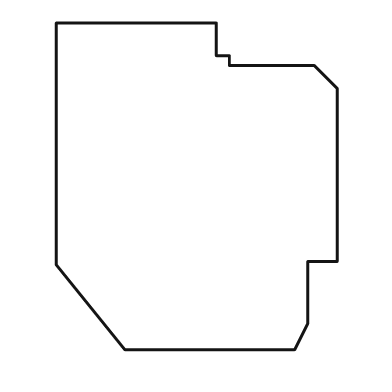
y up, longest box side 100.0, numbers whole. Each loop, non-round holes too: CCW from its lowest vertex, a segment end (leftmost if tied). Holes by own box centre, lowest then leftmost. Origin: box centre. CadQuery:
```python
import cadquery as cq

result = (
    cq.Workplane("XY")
    .moveTo(-22.0, -50.0)
    .lineTo(30.0, -50.0)
    .lineTo(34.0, -42.0)
    .lineTo(34.0, -23.0)
    .lineTo(43.0, -23.0)
    .lineTo(43.0, 30.0)
    .lineTo(36.0, 37.0)
    .lineTo(10.0, 37.0)
    .lineTo(10.0, 40.0)
    .lineTo(6.0, 40.0)
    .lineTo(6.0, 50.0)
    .lineTo(-43.0, 50.0)
    .lineTo(-43.0, -24.0)
    .close()
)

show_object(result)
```